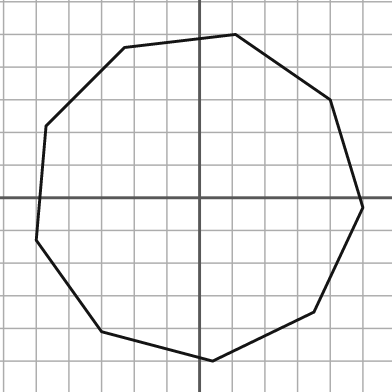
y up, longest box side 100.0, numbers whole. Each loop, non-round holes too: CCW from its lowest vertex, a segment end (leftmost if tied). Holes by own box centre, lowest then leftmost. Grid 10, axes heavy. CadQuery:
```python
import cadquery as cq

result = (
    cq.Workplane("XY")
    .moveTo(4.0, -50.0)
    .lineTo(35.0, -35.0)
    .lineTo(50.0, -3.0)
    .lineTo(40.0, 30.0)
    .lineTo(11.0, 50.0)
    .lineTo(-23.0, 46.0)
    .lineTo(-47.0, 22.0)
    .lineTo(-50.0, -13.0)
    .lineTo(-30.0, -41.0)
    .close()
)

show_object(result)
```